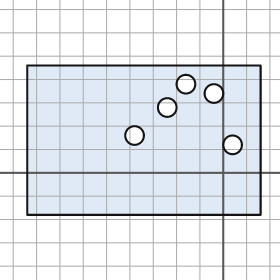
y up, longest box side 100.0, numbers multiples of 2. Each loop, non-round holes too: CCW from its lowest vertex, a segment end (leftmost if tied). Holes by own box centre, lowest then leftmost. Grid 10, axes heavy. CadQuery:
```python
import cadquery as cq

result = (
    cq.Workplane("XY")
    .moveTo(-84.0, -18.0)
    .lineTo(16.0, -18.0)
    .lineTo(16.0, 46.0)
    .lineTo(-84.0, 46.0)
    .close()
    .moveTo(4.0, 12.0)
    .circle(4.0)
    .moveTo(-38.0, 16.0)
    .circle(4.0)
    .moveTo(-24.0, 28.0)
    .circle(4.0)
    .moveTo(-4.0, 34.0)
    .circle(4.0)
    .moveTo(-16.0, 38.0)
    .circle(4.0)
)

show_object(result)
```